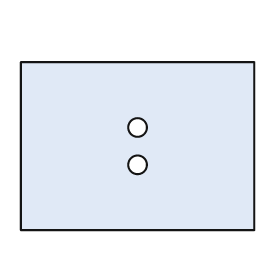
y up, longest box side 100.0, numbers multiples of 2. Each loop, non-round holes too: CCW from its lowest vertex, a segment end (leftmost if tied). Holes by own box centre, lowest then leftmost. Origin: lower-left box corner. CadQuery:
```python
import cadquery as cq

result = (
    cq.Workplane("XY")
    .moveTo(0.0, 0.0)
    .lineTo(100.0, 0.0)
    .lineTo(100.0, 72.0)
    .lineTo(0.0, 72.0)
    .close()
    .moveTo(50.0, 28.0)
    .circle(4.0)
    .moveTo(50.0, 44.0)
    .circle(4.0)
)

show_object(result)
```